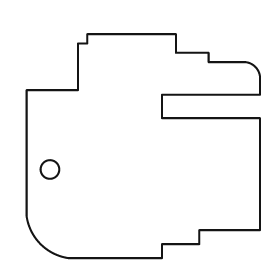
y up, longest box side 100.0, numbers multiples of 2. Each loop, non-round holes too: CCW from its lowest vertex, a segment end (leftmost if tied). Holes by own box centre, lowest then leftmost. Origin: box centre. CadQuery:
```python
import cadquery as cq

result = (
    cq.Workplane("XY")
    .moveTo(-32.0, -48.0)
    .lineTo(8.0, -48.0)
    .lineTo(8.0, -42.0)
    .lineTo(24.0, -42.0)
    .lineTo(24.0, -36.0)
    .lineTo(50.0, -36.0)
    .lineTo(50.0, 12.0)
    .lineTo(8.0, 12.0)
    .lineTo(8.0, 22.0)
    .lineTo(50.0, 22.0)
    .lineTo(50.0, 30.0)
    .threePointArc((48.0, 34.0), (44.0, 36.0))
    .lineTo(28.0, 36.0)
    .lineTo(28.0, 40.0)
    .lineTo(14.0, 40.0)
    .lineTo(14.0, 48.0)
    .lineTo(-24.0, 48.0)
    .lineTo(-24.0, 44.0)
    .lineTo(-28.0, 44.0)
    .lineTo(-28.0, 24.0)
    .lineTo(-50.0, 24.0)
    .lineTo(-50.0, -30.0)
    .threePointArc((-44.0, -42.0), (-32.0, -48.0))
    .close()
    .moveTo(-40.0, -10.0)
    .circle(4.0)
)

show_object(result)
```